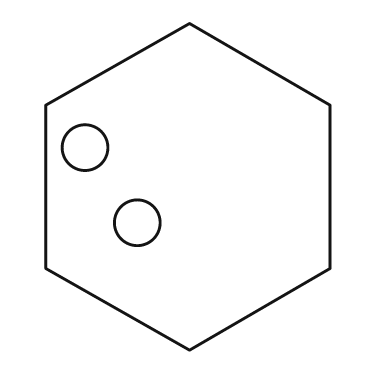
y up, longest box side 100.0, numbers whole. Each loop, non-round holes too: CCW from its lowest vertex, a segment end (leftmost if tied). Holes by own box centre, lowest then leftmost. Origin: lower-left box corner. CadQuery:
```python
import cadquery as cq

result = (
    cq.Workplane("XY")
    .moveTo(44.0, 0.0)
    .lineTo(87.0, 25.0)
    .lineTo(87.0, 75.0)
    .lineTo(44.0, 100.0)
    .lineTo(0.0, 75.0)
    .lineTo(0.0, 25.0)
    .close()
    .moveTo(28.0, 39.0)
    .circle(7.0)
    .moveTo(12.0, 62.0)
    .circle(7.0)
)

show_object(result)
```